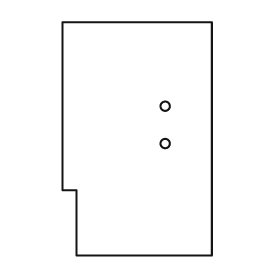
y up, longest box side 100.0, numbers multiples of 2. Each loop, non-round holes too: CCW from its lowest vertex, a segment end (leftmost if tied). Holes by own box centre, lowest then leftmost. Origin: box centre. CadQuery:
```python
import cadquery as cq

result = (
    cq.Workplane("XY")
    .moveTo(-26.0, -50.0)
    .lineTo(32.0, -50.0)
    .lineTo(32.0, 50.0)
    .lineTo(-32.0, 50.0)
    .lineTo(-32.0, -22.0)
    .lineTo(-26.0, -22.0)
    .close()
    .moveTo(12.0, -2.0)
    .circle(2.0)
    .moveTo(12.0, 14.0)
    .circle(2.0)
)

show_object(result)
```